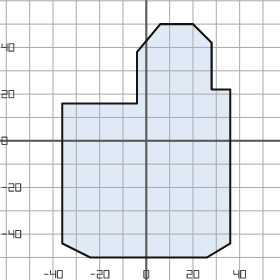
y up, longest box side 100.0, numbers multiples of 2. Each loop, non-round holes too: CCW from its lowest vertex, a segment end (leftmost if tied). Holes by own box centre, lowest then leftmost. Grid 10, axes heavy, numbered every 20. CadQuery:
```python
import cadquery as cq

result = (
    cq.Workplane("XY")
    .moveTo(-24.0, -50.0)
    .lineTo(26.0, -50.0)
    .lineTo(36.0, -44.0)
    .lineTo(36.0, 22.0)
    .lineTo(28.0, 22.0)
    .lineTo(28.0, 42.0)
    .lineTo(20.0, 50.0)
    .lineTo(6.0, 50.0)
    .lineTo(-4.0, 38.0)
    .lineTo(-4.0, 16.0)
    .lineTo(-36.0, 16.0)
    .lineTo(-36.0, -44.0)
    .close()
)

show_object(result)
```